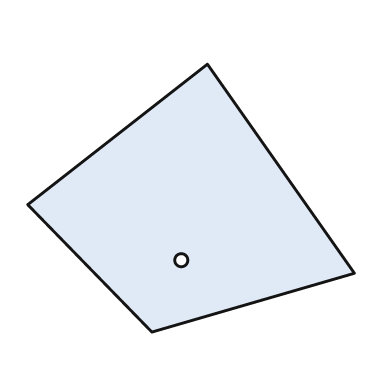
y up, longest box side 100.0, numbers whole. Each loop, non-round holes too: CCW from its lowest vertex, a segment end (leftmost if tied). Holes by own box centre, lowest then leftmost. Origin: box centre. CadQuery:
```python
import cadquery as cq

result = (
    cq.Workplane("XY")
    .moveTo(-12.0, -41.0)
    .lineTo(50.0, -23.0)
    .lineTo(5.0, 41.0)
    .lineTo(-50.0, -2.0)
    .close()
    .moveTo(-3.0, -19.0)
    .circle(2.0)
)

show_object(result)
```